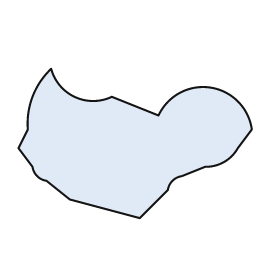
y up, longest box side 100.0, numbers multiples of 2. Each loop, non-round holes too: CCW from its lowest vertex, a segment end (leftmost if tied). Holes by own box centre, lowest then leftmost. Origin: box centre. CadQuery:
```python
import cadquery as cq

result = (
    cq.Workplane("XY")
    .moveTo(2.0, -32.0)
    .lineTo(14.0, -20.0)
    .threePointArc((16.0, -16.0), (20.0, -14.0))
    .lineTo(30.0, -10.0)
    .threePointArc((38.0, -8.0), (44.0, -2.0))
    .lineTo(50.0, 6.0)
    .threePointArc((32.0, 24.0), (10.0, 12.0))
    .lineTo(-10.0, 20.0)
    .threePointArc((-26.0, 20.0), (-36.0, 32.0))
    .threePointArc((-44.0, 20.0), (-46.0, 6.0))
    .lineTo(-50.0, -2.0)
    .lineTo(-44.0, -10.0)
    .threePointArc((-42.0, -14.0), (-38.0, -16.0))
    .lineTo(-28.0, -24.0)
    .close()
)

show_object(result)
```